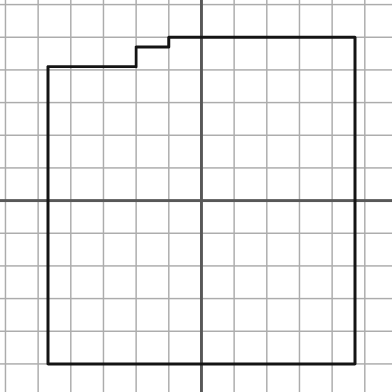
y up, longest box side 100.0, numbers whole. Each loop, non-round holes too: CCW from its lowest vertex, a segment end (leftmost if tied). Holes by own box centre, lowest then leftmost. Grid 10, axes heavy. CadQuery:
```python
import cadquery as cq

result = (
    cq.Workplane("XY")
    .moveTo(-47.0, -50.0)
    .lineTo(47.0, -50.0)
    .lineTo(47.0, 50.0)
    .lineTo(-10.0, 50.0)
    .lineTo(-10.0, 47.0)
    .lineTo(-20.0, 47.0)
    .lineTo(-20.0, 41.0)
    .lineTo(-47.0, 41.0)
    .close()
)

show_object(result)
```